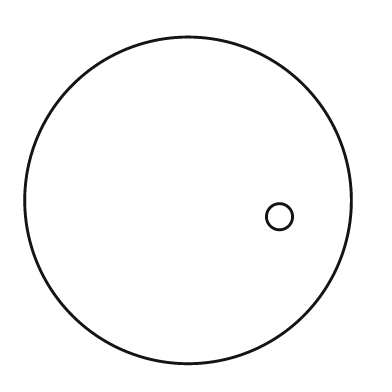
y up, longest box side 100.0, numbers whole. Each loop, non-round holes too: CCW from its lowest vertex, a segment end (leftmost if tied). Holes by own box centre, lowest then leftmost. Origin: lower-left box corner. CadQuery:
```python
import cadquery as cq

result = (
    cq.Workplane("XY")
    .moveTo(50.0, 50.0)
    .circle(50.0)
    .moveTo(78.0, 45.0)
    .circle(4.0)
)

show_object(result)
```